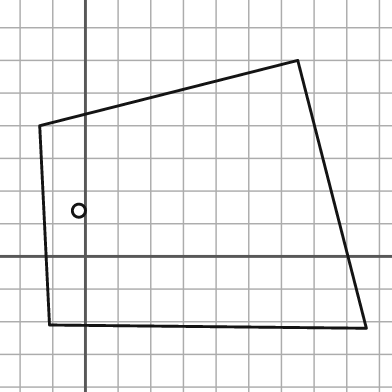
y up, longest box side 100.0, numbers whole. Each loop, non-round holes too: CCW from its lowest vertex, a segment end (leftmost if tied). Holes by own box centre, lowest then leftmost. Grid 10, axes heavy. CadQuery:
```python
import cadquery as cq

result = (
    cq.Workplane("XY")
    .moveTo(86.0, -22.0)
    .lineTo(65.0, 60.0)
    .lineTo(-14.0, 40.0)
    .lineTo(-11.0, -21.0)
    .close()
    .moveTo(-2.0, 14.0)
    .circle(2.0)
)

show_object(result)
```